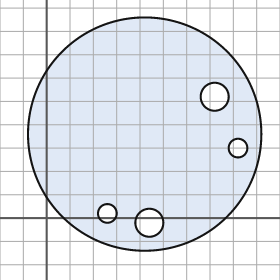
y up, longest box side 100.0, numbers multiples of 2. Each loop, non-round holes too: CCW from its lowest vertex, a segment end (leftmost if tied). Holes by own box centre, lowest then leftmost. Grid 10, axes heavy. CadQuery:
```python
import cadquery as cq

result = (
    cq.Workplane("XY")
    .moveTo(42.0, 36.0)
    .circle(50.0)
    .moveTo(44.0, -2.0)
    .circle(6.0)
    .moveTo(26.0, 2.0)
    .circle(4.0)
    .moveTo(82.0, 30.0)
    .circle(4.0)
    .moveTo(72.0, 52.0)
    .circle(6.0)
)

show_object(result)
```